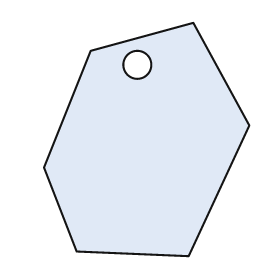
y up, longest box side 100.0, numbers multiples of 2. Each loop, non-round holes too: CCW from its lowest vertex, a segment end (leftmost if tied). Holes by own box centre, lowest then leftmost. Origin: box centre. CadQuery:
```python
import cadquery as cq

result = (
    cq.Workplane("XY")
    .moveTo(18.0, -50.0)
    .lineTo(44.0, 6.0)
    .lineTo(20.0, 50.0)
    .lineTo(-24.0, 38.0)
    .lineTo(-44.0, -12.0)
    .lineTo(-30.0, -48.0)
    .close()
    .moveTo(-4.0, 32.0)
    .circle(6.0)
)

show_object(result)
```